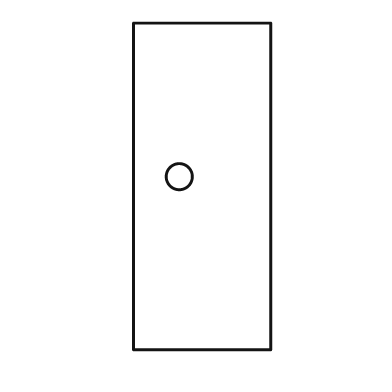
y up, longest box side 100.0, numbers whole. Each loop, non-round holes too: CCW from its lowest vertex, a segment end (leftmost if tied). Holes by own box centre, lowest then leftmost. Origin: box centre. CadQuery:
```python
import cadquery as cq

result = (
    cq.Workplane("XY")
    .moveTo(-21.0, -50.0)
    .lineTo(21.0, -50.0)
    .lineTo(21.0, 50.0)
    .lineTo(-21.0, 50.0)
    .close()
    .moveTo(-7.0, 3.0)
    .circle(4.0)
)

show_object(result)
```